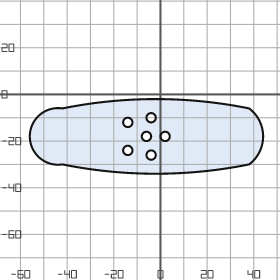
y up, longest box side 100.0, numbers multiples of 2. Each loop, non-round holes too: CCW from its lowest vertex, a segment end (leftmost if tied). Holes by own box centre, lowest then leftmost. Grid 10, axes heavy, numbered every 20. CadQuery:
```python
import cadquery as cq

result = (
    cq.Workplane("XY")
    .moveTo(-42.0, -30.0)
    .threePointArc((-2.0, -34.0), (38.0, -30.0))
    .threePointArc((44.0, -18.0), (38.0, -6.0))
    .threePointArc((-2.0, -2.0), (-42.0, -6.0))
    .threePointArc((-56.0, -18.0), (-42.0, -30.0))
    .close()
    .moveTo(-4.0, -26.0)
    .circle(2.0)
    .moveTo(-14.0, -24.0)
    .circle(2.0)
    .moveTo(-6.0, -18.0)
    .circle(2.0)
    .moveTo(2.0, -18.0)
    .circle(2.0)
    .moveTo(-14.0, -12.0)
    .circle(2.0)
    .moveTo(-4.0, -10.0)
    .circle(2.0)
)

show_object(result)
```